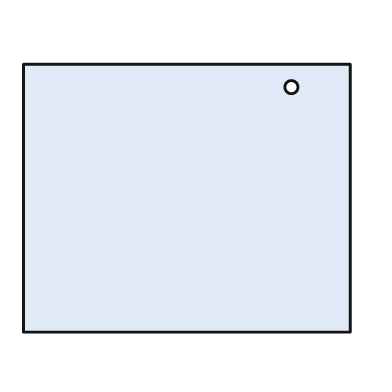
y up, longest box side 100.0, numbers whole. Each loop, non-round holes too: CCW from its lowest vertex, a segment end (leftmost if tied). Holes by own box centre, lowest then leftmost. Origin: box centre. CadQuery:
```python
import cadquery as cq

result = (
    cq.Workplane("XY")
    .moveTo(-50.0, -41.0)
    .lineTo(50.0, -41.0)
    .lineTo(50.0, 41.0)
    .lineTo(-50.0, 41.0)
    .close()
    .moveTo(32.0, 34.0)
    .circle(2.0)
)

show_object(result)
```